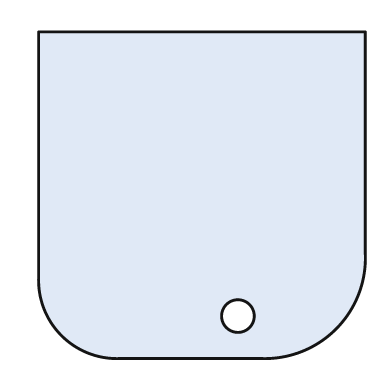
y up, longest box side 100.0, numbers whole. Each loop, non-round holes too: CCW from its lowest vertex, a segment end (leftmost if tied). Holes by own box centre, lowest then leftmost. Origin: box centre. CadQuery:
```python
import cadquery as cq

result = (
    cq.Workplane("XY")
    .moveTo(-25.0, -50.0)
    .lineTo(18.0, -50.0)
    .threePointArc((41.0, -41.0), (50.0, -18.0))
    .lineTo(50.0, 50.0)
    .lineTo(-50.0, 50.0)
    .lineTo(-50.0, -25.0)
    .threePointArc((-43.0, -43.0), (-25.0, -50.0))
    .close()
    .moveTo(11.0, -37.0)
    .circle(5.0)
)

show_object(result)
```